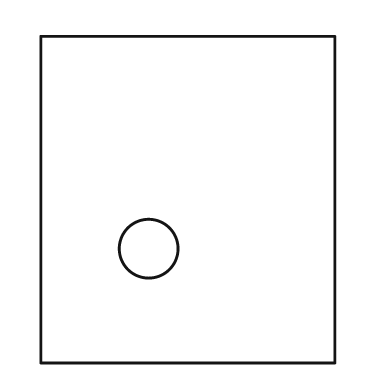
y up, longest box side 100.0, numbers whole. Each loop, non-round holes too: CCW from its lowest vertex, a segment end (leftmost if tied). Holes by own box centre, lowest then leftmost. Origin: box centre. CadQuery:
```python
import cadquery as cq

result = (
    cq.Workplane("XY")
    .moveTo(-45.0, -50.0)
    .lineTo(45.0, -50.0)
    .lineTo(45.0, 50.0)
    .lineTo(-45.0, 50.0)
    .close()
    .moveTo(-12.0, -15.0)
    .circle(9.0)
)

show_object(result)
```